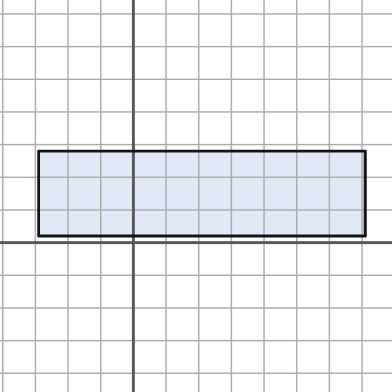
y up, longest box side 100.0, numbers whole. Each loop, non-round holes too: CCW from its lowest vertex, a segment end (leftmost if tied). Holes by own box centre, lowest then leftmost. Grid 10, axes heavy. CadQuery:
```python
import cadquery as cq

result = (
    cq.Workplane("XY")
    .moveTo(-29.0, 2.0)
    .lineTo(71.0, 2.0)
    .lineTo(71.0, 28.0)
    .lineTo(-29.0, 28.0)
    .close()
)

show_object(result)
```